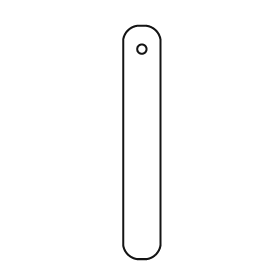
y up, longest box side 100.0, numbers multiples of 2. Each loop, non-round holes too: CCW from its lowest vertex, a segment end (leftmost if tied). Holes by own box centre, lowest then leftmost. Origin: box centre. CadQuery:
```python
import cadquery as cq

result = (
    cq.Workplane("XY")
    .moveTo(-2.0, -50.0)
    .lineTo(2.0, -50.0)
    .threePointArc((6.0, -48.0), (8.0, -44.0))
    .lineTo(8.0, 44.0)
    .threePointArc((6.0, 48.0), (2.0, 50.0))
    .lineTo(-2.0, 50.0)
    .threePointArc((-6.0, 48.0), (-8.0, 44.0))
    .lineTo(-8.0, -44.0)
    .threePointArc((-6.0, -48.0), (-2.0, -50.0))
    .close()
    .moveTo(0.0, 40.0)
    .circle(2.0)
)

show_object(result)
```